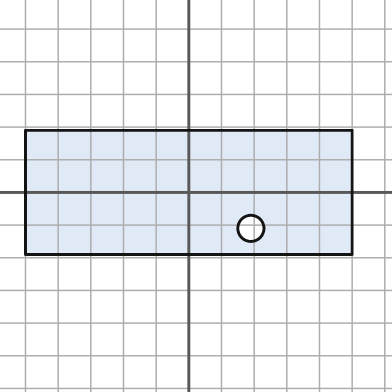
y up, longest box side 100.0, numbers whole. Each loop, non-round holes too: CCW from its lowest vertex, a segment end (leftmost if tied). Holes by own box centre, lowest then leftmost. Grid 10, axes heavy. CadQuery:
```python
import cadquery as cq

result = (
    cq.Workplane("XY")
    .moveTo(-50.0, -19.0)
    .lineTo(50.0, -19.0)
    .lineTo(50.0, 19.0)
    .lineTo(-50.0, 19.0)
    .close()
    .moveTo(19.0, -11.0)
    .circle(4.0)
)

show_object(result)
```